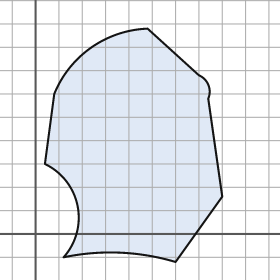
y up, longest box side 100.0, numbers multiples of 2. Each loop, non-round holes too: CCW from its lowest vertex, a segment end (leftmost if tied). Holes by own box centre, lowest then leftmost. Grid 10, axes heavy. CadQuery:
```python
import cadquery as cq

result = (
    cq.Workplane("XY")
    .moveTo(60.0, -12.0)
    .lineTo(80.0, 16.0)
    .lineTo(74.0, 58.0)
    .threePointArc((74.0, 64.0), (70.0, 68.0))
    .lineTo(48.0, 88.0)
    .threePointArc((24.0, 80.0), (8.0, 60.0))
    .lineTo(4.0, 30.0)
    .threePointArc((18.0, 12.0), (12.0, -10.0))
    .threePointArc((36.0, -8.0), (60.0, -12.0))
    .close()
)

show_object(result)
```